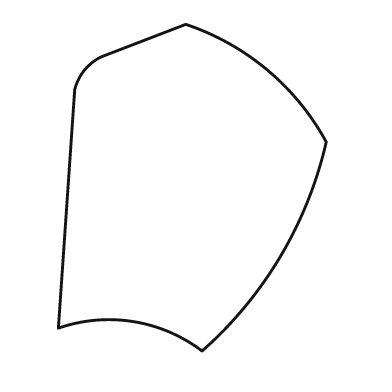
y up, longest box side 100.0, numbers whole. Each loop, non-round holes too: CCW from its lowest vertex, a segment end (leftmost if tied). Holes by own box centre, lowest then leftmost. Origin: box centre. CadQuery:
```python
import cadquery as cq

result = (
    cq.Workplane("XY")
    .moveTo(3.0, -50.0)
    .threePointArc((27.0, -21.0), (41.0, 14.0))
    .threePointArc((23.0, 36.0), (-2.0, 50.0))
    .lineTo(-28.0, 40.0)
    .threePointArc((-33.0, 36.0), (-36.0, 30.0))
    .lineTo(-41.0, -43.0)
    .threePointArc((-18.0, -41.0), (3.0, -50.0))
    .close()
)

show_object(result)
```